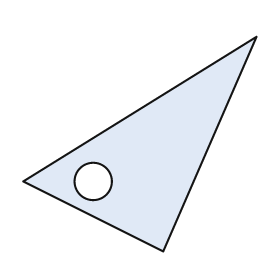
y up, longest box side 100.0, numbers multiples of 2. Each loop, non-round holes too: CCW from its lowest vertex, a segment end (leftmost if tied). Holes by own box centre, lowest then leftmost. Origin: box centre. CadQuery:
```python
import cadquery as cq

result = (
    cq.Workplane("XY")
    .moveTo(10.0, -46.0)
    .lineTo(50.0, 46.0)
    .lineTo(-50.0, -16.0)
    .close()
    .moveTo(-20.0, -16.0)
    .circle(8.0)
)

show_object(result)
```